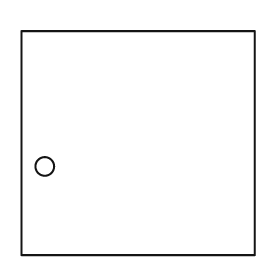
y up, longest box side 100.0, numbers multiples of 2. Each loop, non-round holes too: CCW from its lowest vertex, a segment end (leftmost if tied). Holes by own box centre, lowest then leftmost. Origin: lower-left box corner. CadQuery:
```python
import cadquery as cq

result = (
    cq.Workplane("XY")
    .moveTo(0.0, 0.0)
    .lineTo(100.0, 0.0)
    .lineTo(100.0, 96.0)
    .lineTo(0.0, 96.0)
    .close()
    .moveTo(10.0, 38.0)
    .circle(4.0)
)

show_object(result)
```